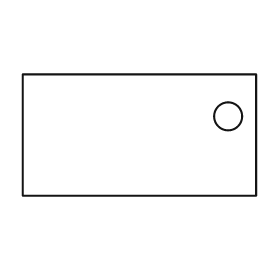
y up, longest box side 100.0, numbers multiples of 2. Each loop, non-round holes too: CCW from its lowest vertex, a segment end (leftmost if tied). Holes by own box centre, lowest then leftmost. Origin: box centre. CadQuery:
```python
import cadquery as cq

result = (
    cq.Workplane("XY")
    .moveTo(-50.0, -26.0)
    .lineTo(50.0, -26.0)
    .lineTo(50.0, 26.0)
    .lineTo(-50.0, 26.0)
    .close()
    .moveTo(38.0, 8.0)
    .circle(6.0)
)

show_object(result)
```